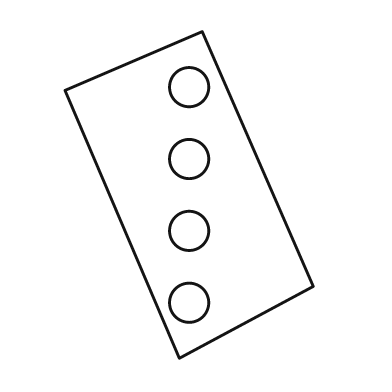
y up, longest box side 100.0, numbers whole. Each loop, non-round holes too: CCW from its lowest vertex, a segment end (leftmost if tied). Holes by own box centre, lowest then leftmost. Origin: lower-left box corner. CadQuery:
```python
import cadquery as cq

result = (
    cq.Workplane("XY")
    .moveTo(35.0, 0.0)
    .lineTo(76.0, 22.0)
    .lineTo(42.0, 100.0)
    .lineTo(0.0, 82.0)
    .close()
    .moveTo(38.0, 17.0)
    .circle(6.0)
    .moveTo(38.0, 39.0)
    .circle(6.0)
    .moveTo(38.0, 61.0)
    .circle(6.0)
    .moveTo(38.0, 83.0)
    .circle(6.0)
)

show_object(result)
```